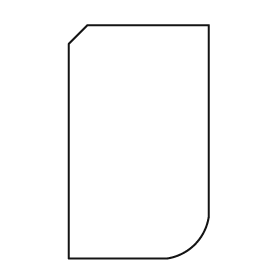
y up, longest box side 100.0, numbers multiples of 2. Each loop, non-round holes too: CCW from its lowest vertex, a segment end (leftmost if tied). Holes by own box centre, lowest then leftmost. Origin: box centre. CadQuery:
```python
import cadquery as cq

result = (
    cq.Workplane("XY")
    .moveTo(-30.0, -50.0)
    .lineTo(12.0, -50.0)
    .threePointArc((24.0, -44.0), (30.0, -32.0))
    .lineTo(30.0, 50.0)
    .lineTo(-22.0, 50.0)
    .lineTo(-30.0, 42.0)
    .close()
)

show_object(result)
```